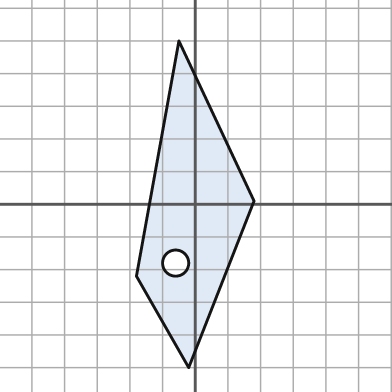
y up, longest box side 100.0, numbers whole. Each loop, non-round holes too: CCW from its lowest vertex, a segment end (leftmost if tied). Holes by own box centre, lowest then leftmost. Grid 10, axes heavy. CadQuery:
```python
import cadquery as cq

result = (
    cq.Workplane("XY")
    .moveTo(-2.0, -50.0)
    .lineTo(18.0, 1.0)
    .lineTo(-5.0, 50.0)
    .lineTo(-18.0, -22.0)
    .close()
    .moveTo(-6.0, -18.0)
    .circle(4.0)
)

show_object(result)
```